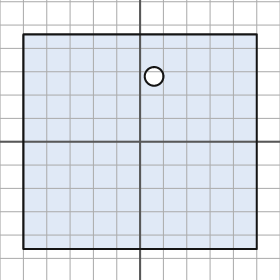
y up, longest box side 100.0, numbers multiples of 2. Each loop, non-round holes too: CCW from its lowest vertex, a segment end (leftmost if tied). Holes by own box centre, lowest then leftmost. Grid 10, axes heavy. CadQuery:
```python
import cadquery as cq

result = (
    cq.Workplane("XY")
    .moveTo(-50.0, -46.0)
    .lineTo(50.0, -46.0)
    .lineTo(50.0, 46.0)
    .lineTo(-50.0, 46.0)
    .close()
    .moveTo(6.0, 28.0)
    .circle(4.0)
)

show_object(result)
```